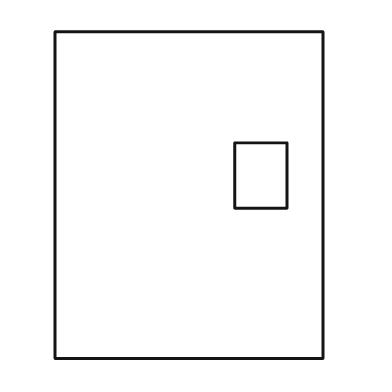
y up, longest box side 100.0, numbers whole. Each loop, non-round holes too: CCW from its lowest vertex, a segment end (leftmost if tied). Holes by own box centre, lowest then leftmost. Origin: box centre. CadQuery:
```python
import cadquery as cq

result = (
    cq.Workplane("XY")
    .moveTo(-41.0, -50.0)
    .lineTo(41.0, -50.0)
    .lineTo(41.0, 50.0)
    .lineTo(-41.0, 50.0)
    .close()
    .moveTo(14.0, -4.0)
    .lineTo(30.0, -4.0)
    .lineTo(30.0, 16.0)
    .lineTo(14.0, 16.0)
    .close()
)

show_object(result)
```